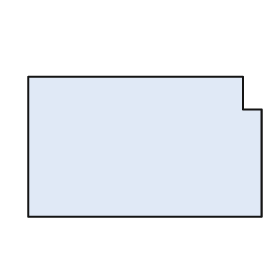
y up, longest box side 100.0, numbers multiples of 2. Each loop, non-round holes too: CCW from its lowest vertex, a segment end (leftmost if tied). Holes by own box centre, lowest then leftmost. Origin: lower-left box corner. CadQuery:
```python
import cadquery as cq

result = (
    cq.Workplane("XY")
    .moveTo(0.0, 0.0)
    .lineTo(100.0, 0.0)
    .lineTo(100.0, 46.0)
    .lineTo(92.0, 46.0)
    .lineTo(92.0, 60.0)
    .lineTo(0.0, 60.0)
    .close()
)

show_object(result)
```